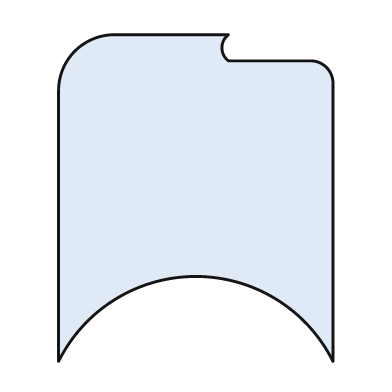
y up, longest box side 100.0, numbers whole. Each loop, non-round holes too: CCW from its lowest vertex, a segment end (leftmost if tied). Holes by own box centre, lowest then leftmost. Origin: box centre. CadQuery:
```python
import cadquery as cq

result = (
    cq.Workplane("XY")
    .moveTo(-42.0, -50.0)
    .threePointArc((0.0, -24.0), (42.0, -50.0))
    .lineTo(42.0, 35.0)
    .threePointArc((40.0, 40.0), (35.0, 42.0))
    .lineTo(10.0, 42.0)
    .threePointArc((8.0, 46.0), (10.0, 50.0))
    .lineTo(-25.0, 50.0)
    .threePointArc((-37.0, 45.0), (-42.0, 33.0))
    .close()
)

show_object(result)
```